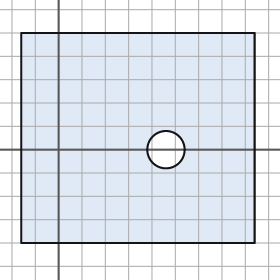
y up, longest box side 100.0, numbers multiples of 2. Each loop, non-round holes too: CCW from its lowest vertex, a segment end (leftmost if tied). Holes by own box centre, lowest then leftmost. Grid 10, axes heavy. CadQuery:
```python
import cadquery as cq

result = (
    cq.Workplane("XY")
    .moveTo(-16.0, -40.0)
    .lineTo(84.0, -40.0)
    .lineTo(84.0, 50.0)
    .lineTo(-16.0, 50.0)
    .close()
    .moveTo(46.0, 0.0)
    .circle(8.0)
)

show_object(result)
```